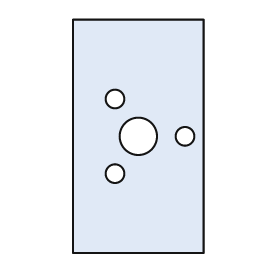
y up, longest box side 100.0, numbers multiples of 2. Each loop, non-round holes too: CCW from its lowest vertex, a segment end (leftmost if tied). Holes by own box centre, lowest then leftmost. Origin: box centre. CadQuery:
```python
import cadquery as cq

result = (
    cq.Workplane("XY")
    .moveTo(-28.0, -50.0)
    .lineTo(28.0, -50.0)
    .lineTo(28.0, 50.0)
    .lineTo(-28.0, 50.0)
    .close()
    .moveTo(-10.0, -16.0)
    .circle(4.0)
    .moveTo(0.0, 0.0)
    .circle(8.0)
    .moveTo(20.0, 0.0)
    .circle(4.0)
    .moveTo(-10.0, 16.0)
    .circle(4.0)
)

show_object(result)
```